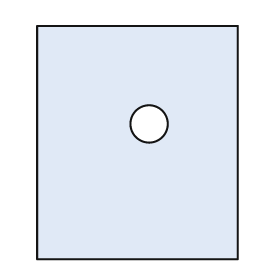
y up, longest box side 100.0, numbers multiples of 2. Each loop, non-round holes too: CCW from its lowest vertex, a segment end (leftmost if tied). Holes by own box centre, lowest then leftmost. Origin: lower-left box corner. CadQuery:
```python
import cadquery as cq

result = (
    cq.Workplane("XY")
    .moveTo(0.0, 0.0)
    .lineTo(86.0, 0.0)
    .lineTo(86.0, 100.0)
    .lineTo(0.0, 100.0)
    .close()
    .moveTo(48.0, 58.0)
    .circle(8.0)
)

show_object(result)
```